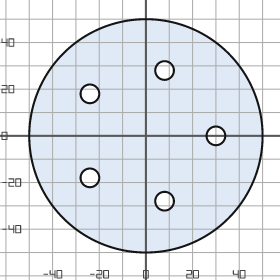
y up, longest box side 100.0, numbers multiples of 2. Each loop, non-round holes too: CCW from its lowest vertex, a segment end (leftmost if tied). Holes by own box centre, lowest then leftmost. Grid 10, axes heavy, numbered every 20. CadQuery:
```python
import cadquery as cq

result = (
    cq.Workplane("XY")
    .moveTo(0.0, 0.0)
    .circle(50.0)
    .moveTo(8.0, -28.0)
    .circle(4.0)
    .moveTo(-24.0, -18.0)
    .circle(4.0)
    .moveTo(30.0, 0.0)
    .circle(4.0)
    .moveTo(-24.0, 18.0)
    .circle(4.0)
    .moveTo(8.0, 28.0)
    .circle(4.0)
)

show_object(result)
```